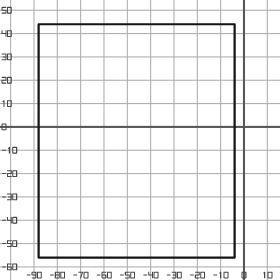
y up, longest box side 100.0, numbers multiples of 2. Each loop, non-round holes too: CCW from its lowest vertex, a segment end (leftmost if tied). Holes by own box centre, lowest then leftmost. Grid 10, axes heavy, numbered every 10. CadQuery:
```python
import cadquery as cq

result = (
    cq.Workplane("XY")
    .moveTo(-88.0, -56.0)
    .lineTo(-4.0, -56.0)
    .lineTo(-4.0, 44.0)
    .lineTo(-88.0, 44.0)
    .close()
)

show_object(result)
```